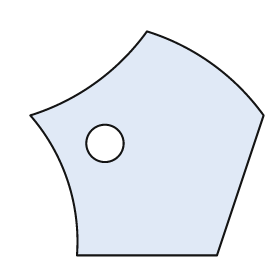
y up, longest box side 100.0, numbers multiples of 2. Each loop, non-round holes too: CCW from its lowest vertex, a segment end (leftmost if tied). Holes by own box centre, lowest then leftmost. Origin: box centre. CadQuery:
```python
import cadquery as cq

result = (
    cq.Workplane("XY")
    .moveTo(-30.0, -48.0)
    .lineTo(30.0, -48.0)
    .lineTo(50.0, 12.0)
    .threePointArc((28.0, 34.0), (0.0, 48.0))
    .threePointArc((-22.0, 26.0), (-50.0, 12.0))
    .threePointArc((-34.0, -16.0), (-30.0, -48.0))
    .close()
    .moveTo(-18.0, 0.0)
    .circle(8.0)
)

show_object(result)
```